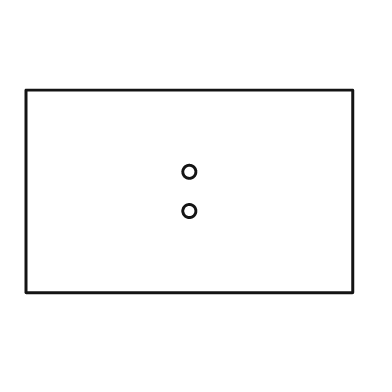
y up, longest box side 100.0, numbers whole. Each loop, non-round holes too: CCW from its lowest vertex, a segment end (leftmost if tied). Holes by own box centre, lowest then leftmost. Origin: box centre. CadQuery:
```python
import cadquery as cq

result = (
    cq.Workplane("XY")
    .moveTo(-50.0, -31.0)
    .lineTo(50.0, -31.0)
    .lineTo(50.0, 31.0)
    .lineTo(-50.0, 31.0)
    .close()
    .moveTo(0.0, -6.0)
    .circle(2.0)
    .moveTo(0.0, 6.0)
    .circle(2.0)
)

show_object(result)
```